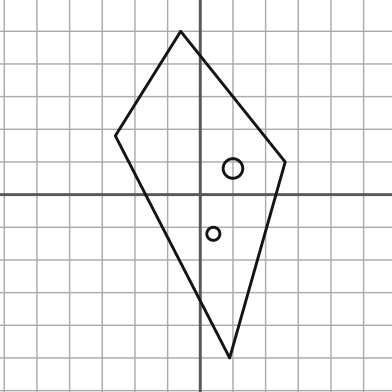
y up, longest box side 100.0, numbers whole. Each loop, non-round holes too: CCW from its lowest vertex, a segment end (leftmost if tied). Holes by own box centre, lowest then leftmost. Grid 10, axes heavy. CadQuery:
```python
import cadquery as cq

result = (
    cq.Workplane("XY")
    .moveTo(9.0, -50.0)
    .lineTo(26.0, 10.0)
    .lineTo(-6.0, 50.0)
    .lineTo(-26.0, 18.0)
    .close()
    .moveTo(4.0, -12.0)
    .circle(2.0)
    .moveTo(10.0, 8.0)
    .circle(3.0)
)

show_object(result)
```